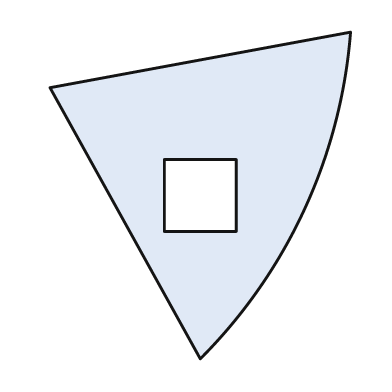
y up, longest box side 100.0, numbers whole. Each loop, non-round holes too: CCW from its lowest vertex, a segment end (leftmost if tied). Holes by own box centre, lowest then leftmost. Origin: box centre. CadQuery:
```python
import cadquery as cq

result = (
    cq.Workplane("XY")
    .moveTo(0.0, -50.0)
    .threePointArc((32.0, -4.0), (46.0, 50.0))
    .lineTo(-46.0, 33.0)
    .close()
    .moveTo(-11.0, -11.0)
    .lineTo(11.0, -11.0)
    .lineTo(11.0, 11.0)
    .lineTo(-11.0, 11.0)
    .close()
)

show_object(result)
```